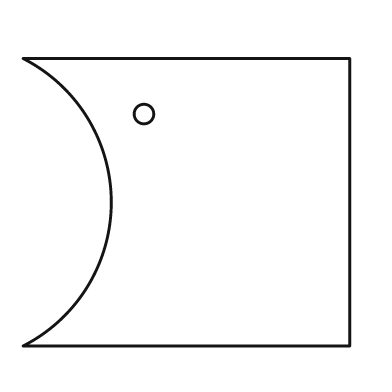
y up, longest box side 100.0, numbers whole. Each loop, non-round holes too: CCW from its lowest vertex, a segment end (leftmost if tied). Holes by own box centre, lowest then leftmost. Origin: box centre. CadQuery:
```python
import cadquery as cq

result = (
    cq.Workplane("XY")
    .moveTo(-50.0, -44.0)
    .lineTo(50.0, -44.0)
    .lineTo(50.0, 44.0)
    .lineTo(-50.0, 44.0)
    .threePointArc((-23.0, 0.0), (-50.0, -44.0))
    .close()
    .moveTo(-13.0, 27.0)
    .circle(3.0)
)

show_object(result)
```